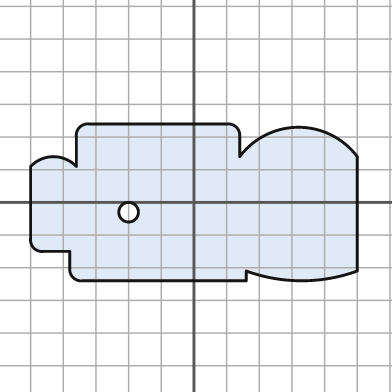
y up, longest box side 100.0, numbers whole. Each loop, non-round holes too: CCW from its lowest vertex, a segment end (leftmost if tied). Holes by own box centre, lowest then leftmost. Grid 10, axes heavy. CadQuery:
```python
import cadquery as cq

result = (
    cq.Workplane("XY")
    .moveTo(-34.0, -24.0)
    .lineTo(16.0, -24.0)
    .lineTo(16.0, -21.0)
    .threePointArc((33.0, -24.0), (50.0, -21.0))
    .lineTo(50.0, 14.0)
    .threePointArc((32.0, 23.0), (14.0, 14.0))
    .lineTo(14.0, 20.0)
    .threePointArc((13.0, 23.0), (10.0, 24.0))
    .lineTo(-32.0, 24.0)
    .threePointArc((-35.0, 23.0), (-36.0, 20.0))
    .lineTo(-36.0, 11.0)
    .threePointArc((-43.0, 14.0), (-50.0, 11.0))
    .lineTo(-50.0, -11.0)
    .threePointArc((-49.0, -14.0), (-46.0, -15.0))
    .lineTo(-38.0, -15.0)
    .lineTo(-38.0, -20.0)
    .threePointArc((-37.0, -23.0), (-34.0, -24.0))
    .close()
    .moveTo(-20.0, -3.0)
    .circle(3.0)
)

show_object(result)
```